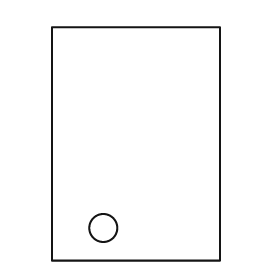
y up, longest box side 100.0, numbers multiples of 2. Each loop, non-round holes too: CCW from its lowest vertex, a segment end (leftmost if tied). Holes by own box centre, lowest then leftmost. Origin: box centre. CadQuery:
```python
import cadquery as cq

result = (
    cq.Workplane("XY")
    .moveTo(-36.0, -50.0)
    .lineTo(36.0, -50.0)
    .lineTo(36.0, 50.0)
    .lineTo(-36.0, 50.0)
    .close()
    .moveTo(-14.0, -36.0)
    .circle(6.0)
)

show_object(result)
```